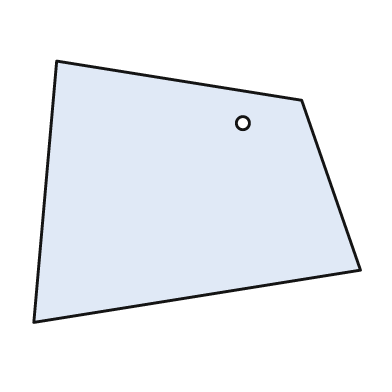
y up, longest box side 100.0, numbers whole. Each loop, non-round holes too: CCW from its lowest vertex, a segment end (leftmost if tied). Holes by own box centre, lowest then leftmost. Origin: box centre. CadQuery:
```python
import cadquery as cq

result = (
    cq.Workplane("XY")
    .moveTo(-50.0, -40.0)
    .lineTo(50.0, -24.0)
    .lineTo(32.0, 28.0)
    .lineTo(-43.0, 40.0)
    .close()
    .moveTo(14.0, 21.0)
    .circle(2.0)
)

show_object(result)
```